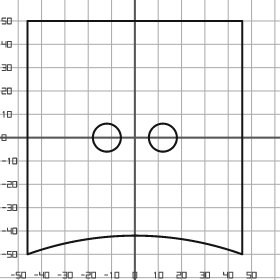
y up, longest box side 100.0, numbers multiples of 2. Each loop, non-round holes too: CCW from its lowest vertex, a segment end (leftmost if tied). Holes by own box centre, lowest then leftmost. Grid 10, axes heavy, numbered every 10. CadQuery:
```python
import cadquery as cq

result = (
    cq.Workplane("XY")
    .moveTo(-46.0, -50.0)
    .threePointArc((0.0, -42.0), (46.0, -50.0))
    .lineTo(46.0, 50.0)
    .lineTo(-46.0, 50.0)
    .close()
    .moveTo(-12.0, 0.0)
    .circle(6.0)
    .moveTo(12.0, 0.0)
    .circle(6.0)
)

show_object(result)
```